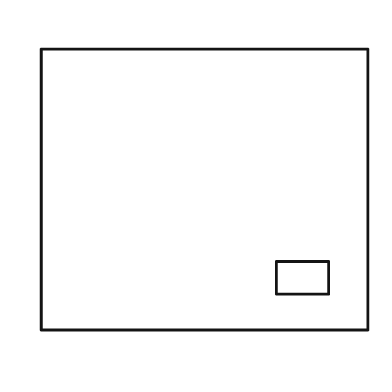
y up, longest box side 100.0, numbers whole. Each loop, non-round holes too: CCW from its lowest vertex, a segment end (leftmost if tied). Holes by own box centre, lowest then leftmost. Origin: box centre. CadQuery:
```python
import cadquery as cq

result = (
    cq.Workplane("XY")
    .moveTo(-50.0, -43.0)
    .lineTo(50.0, -43.0)
    .lineTo(50.0, 43.0)
    .lineTo(-50.0, 43.0)
    .close()
    .moveTo(22.0, -32.0)
    .lineTo(38.0, -32.0)
    .lineTo(38.0, -22.0)
    .lineTo(22.0, -22.0)
    .close()
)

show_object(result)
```